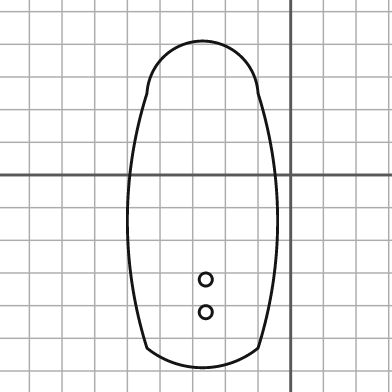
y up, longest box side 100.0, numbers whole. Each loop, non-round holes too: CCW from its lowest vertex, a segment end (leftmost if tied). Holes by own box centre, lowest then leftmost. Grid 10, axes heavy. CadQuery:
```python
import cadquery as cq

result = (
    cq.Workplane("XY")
    .moveTo(-44.0, -53.0)
    .threePointArc((-27.0, -59.0), (-10.0, -53.0))
    .threePointArc((-4.0, -14.0), (-10.0, 25.0))
    .threePointArc((-27.0, 41.0), (-44.0, 25.0))
    .threePointArc((-50.0, -14.0), (-44.0, -53.0))
    .close()
    .moveTo(-26.0, -42.0)
    .circle(2.0)
    .moveTo(-26.0, -32.0)
    .circle(2.0)
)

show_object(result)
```